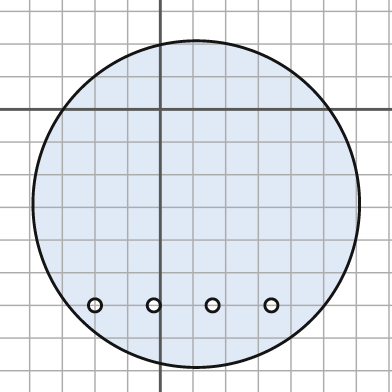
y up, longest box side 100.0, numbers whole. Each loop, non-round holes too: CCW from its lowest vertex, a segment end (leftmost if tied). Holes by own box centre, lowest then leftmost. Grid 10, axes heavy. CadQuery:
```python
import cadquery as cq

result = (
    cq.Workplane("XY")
    .moveTo(11.0, -29.0)
    .circle(50.0)
    .moveTo(-20.0, -60.0)
    .circle(2.0)
    .moveTo(-2.0, -60.0)
    .circle(2.0)
    .moveTo(16.0, -60.0)
    .circle(2.0)
    .moveTo(34.0, -60.0)
    .circle(2.0)
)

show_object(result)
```